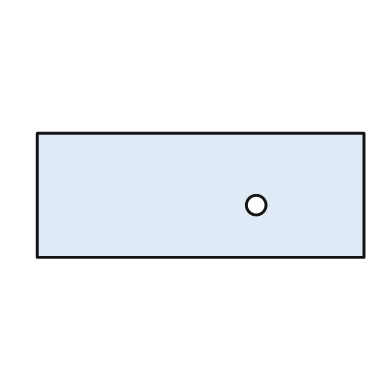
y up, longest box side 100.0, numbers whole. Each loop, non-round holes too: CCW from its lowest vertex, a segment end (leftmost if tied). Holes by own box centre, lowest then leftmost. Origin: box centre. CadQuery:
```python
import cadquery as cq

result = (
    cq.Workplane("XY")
    .moveTo(-50.0, -19.0)
    .lineTo(50.0, -19.0)
    .lineTo(50.0, 19.0)
    .lineTo(-50.0, 19.0)
    .close()
    .moveTo(17.0, -3.0)
    .circle(3.0)
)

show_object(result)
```